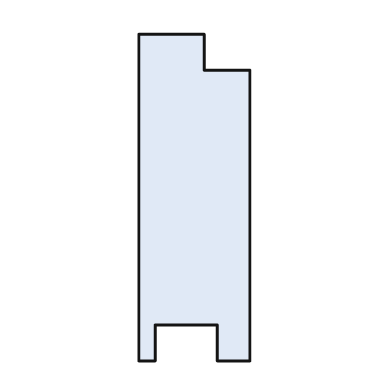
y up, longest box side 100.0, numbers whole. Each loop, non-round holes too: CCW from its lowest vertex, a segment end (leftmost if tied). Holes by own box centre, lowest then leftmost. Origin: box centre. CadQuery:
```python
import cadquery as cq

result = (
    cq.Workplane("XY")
    .moveTo(-17.0, -50.0)
    .lineTo(-12.0, -50.0)
    .lineTo(-12.0, -39.0)
    .lineTo(7.0, -39.0)
    .lineTo(7.0, -50.0)
    .lineTo(17.0, -50.0)
    .lineTo(17.0, 39.0)
    .lineTo(3.0, 39.0)
    .lineTo(3.0, 50.0)
    .lineTo(-17.0, 50.0)
    .close()
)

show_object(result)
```